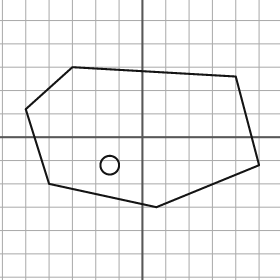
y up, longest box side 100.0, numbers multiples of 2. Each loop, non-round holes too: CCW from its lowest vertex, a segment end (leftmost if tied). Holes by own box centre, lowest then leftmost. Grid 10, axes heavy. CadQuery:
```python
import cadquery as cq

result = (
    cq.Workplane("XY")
    .moveTo(6.0, -30.0)
    .lineTo(50.0, -12.0)
    .lineTo(40.0, 26.0)
    .lineTo(-30.0, 30.0)
    .lineTo(-50.0, 12.0)
    .lineTo(-40.0, -20.0)
    .close()
    .moveTo(-14.0, -12.0)
    .circle(4.0)
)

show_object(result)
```